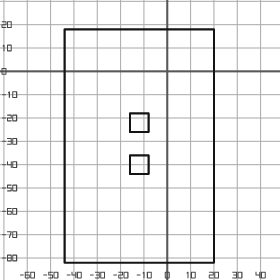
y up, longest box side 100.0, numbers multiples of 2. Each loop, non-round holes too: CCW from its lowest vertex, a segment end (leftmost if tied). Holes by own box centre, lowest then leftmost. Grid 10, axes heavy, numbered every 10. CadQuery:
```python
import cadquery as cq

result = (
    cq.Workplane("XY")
    .moveTo(-44.0, -82.0)
    .lineTo(20.0, -82.0)
    .lineTo(20.0, 18.0)
    .lineTo(-44.0, 18.0)
    .close()
    .moveTo(-16.0, -44.0)
    .lineTo(-8.0, -44.0)
    .lineTo(-8.0, -36.0)
    .lineTo(-16.0, -36.0)
    .close()
    .moveTo(-16.0, -26.0)
    .lineTo(-8.0, -26.0)
    .lineTo(-8.0, -18.0)
    .lineTo(-16.0, -18.0)
    .close()
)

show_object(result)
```